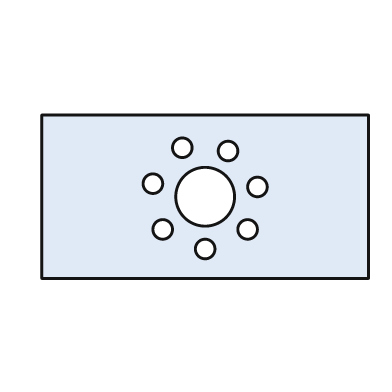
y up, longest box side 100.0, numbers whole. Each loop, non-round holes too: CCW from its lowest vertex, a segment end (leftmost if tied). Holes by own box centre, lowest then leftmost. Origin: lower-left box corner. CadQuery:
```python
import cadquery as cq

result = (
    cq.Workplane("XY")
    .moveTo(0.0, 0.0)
    .lineTo(100.0, 0.0)
    .lineTo(100.0, 50.0)
    .lineTo(0.0, 50.0)
    .close()
    .moveTo(50.0, 9.0)
    .circle(3.0)
    .moveTo(37.0, 15.0)
    .circle(3.0)
    .moveTo(63.0, 15.0)
    .circle(3.0)
    .moveTo(50.0, 25.0)
    .circle(9.0)
    .moveTo(66.0, 28.0)
    .circle(3.0)
    .moveTo(34.0, 29.0)
    .circle(3.0)
    .moveTo(57.0, 39.0)
    .circle(3.0)
    .moveTo(43.0, 40.0)
    .circle(3.0)
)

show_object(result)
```